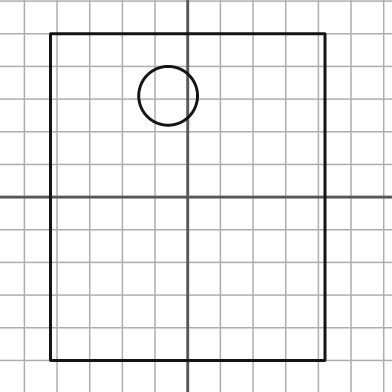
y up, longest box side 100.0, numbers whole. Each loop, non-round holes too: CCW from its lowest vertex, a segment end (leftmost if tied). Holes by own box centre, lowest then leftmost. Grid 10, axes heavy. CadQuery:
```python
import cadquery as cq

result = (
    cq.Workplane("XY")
    .moveTo(-42.0, -50.0)
    .lineTo(42.0, -50.0)
    .lineTo(42.0, 50.0)
    .lineTo(-42.0, 50.0)
    .close()
    .moveTo(-6.0, 31.0)
    .circle(9.0)
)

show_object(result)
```